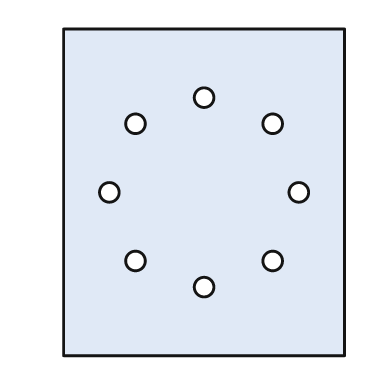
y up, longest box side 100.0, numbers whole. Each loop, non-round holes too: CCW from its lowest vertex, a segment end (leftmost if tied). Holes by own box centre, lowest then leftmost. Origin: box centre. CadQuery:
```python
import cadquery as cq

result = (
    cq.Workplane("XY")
    .moveTo(-43.0, -50.0)
    .lineTo(43.0, -50.0)
    .lineTo(43.0, 50.0)
    .lineTo(-43.0, 50.0)
    .close()
    .moveTo(0.0, -29.0)
    .circle(3.0)
    .moveTo(-21.0, -21.0)
    .circle(3.0)
    .moveTo(21.0, -21.0)
    .circle(3.0)
    .moveTo(-29.0, 0.0)
    .circle(3.0)
    .moveTo(29.0, 0.0)
    .circle(3.0)
    .moveTo(-21.0, 21.0)
    .circle(3.0)
    .moveTo(21.0, 21.0)
    .circle(3.0)
    .moveTo(0.0, 29.0)
    .circle(3.0)
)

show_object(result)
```